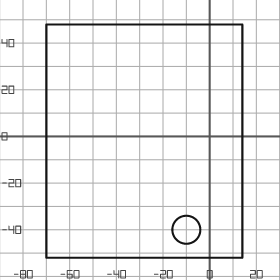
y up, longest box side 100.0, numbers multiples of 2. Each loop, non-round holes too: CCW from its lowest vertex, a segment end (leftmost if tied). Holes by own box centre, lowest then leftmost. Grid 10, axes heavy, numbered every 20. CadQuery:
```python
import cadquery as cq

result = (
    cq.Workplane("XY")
    .moveTo(-70.0, -52.0)
    .lineTo(14.0, -52.0)
    .lineTo(14.0, 48.0)
    .lineTo(-70.0, 48.0)
    .close()
    .moveTo(-10.0, -40.0)
    .circle(6.0)
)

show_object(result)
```